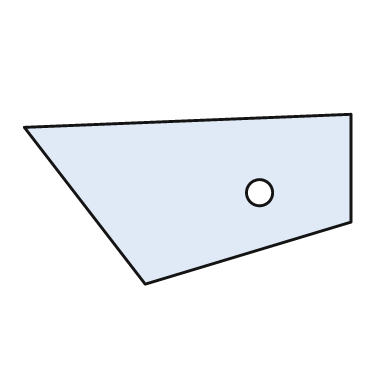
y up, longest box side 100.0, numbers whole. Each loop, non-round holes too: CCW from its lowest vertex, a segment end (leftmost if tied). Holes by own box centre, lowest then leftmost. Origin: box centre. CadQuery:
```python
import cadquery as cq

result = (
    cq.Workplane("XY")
    .moveTo(-13.0, -26.0)
    .lineTo(50.0, -7.0)
    .lineTo(50.0, 26.0)
    .lineTo(-50.0, 22.0)
    .close()
    .moveTo(22.0, 2.0)
    .circle(4.0)
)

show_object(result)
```